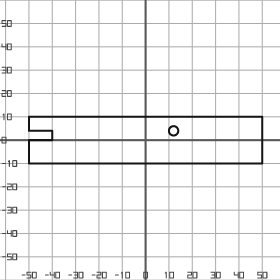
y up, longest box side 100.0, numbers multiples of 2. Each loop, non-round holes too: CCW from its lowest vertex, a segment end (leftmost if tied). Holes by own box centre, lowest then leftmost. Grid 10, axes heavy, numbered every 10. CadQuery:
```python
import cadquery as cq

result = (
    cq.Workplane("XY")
    .moveTo(-50.0, -10.0)
    .lineTo(50.0, -10.0)
    .lineTo(50.0, 10.0)
    .lineTo(-50.0, 10.0)
    .lineTo(-50.0, 4.0)
    .lineTo(-40.0, 4.0)
    .lineTo(-40.0, 0.0)
    .lineTo(-50.0, 0.0)
    .close()
    .moveTo(12.0, 4.0)
    .circle(2.0)
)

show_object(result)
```